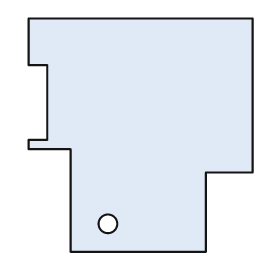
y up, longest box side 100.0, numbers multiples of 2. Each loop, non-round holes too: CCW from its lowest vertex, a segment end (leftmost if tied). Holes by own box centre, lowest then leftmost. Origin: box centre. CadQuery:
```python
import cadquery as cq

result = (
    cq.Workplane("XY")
    .moveTo(-30.0, -50.0)
    .lineTo(28.0, -50.0)
    .lineTo(28.0, -16.0)
    .lineTo(48.0, -16.0)
    .lineTo(48.0, 50.0)
    .lineTo(-48.0, 50.0)
    .lineTo(-48.0, 30.0)
    .lineTo(-40.0, 30.0)
    .lineTo(-40.0, -2.0)
    .lineTo(-48.0, -2.0)
    .lineTo(-48.0, -6.0)
    .lineTo(-30.0, -6.0)
    .close()
    .moveTo(-14.0, -38.0)
    .circle(4.0)
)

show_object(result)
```